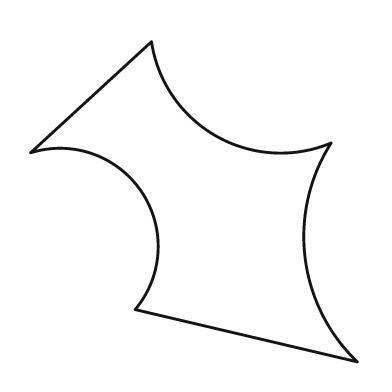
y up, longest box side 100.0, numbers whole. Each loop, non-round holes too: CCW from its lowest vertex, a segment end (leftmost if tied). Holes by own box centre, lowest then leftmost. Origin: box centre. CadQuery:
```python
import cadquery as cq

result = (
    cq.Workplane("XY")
    .moveTo(50.0, -49.0)
    .threePointArc((34.0, -17.0), (42.0, 18.0))
    .threePointArc((7.0, 20.0), (-13.0, 49.0))
    .lineTo(-50.0, 15.0)
    .threePointArc((-16.0, 3.0), (-18.0, -33.0))
    .close()
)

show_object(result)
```